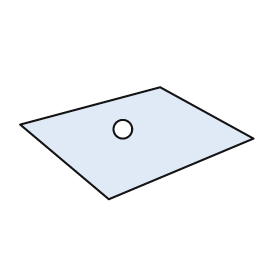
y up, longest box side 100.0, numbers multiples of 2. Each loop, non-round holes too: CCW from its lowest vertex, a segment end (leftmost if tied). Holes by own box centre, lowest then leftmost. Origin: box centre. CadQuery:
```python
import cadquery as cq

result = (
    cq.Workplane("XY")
    .moveTo(-12.0, -24.0)
    .lineTo(50.0, 2.0)
    .lineTo(10.0, 24.0)
    .lineTo(-50.0, 8.0)
    .close()
    .moveTo(-6.0, 6.0)
    .circle(4.0)
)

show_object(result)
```